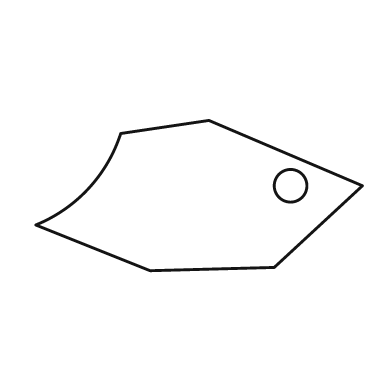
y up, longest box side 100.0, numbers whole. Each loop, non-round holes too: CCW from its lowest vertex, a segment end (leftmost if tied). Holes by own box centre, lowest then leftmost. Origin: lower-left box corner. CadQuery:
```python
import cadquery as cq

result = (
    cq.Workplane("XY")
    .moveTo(35.0, 0.0)
    .lineTo(73.0, 1.0)
    .lineTo(100.0, 26.0)
    .lineTo(53.0, 46.0)
    .lineTo(26.0, 42.0)
    .threePointArc((16.0, 25.0), (0.0, 14.0))
    .close()
    .moveTo(78.0, 26.0)
    .circle(5.0)
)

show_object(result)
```